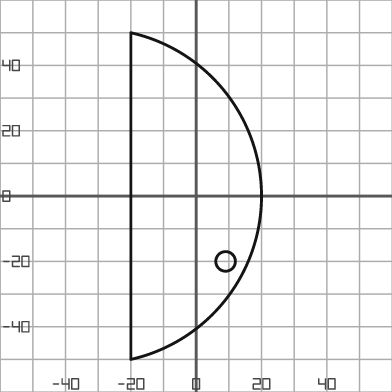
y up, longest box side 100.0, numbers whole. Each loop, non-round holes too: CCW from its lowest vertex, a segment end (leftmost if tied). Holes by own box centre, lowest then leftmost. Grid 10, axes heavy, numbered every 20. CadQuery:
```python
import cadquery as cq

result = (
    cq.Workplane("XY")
    .moveTo(-20.0, -50.0)
    .threePointArc((20.0, 0.0), (-20.0, 50.0))
    .close()
    .moveTo(9.0, -20.0)
    .circle(3.0)
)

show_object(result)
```